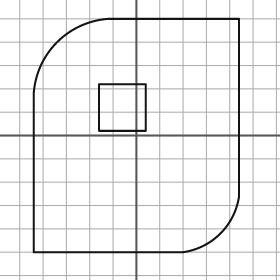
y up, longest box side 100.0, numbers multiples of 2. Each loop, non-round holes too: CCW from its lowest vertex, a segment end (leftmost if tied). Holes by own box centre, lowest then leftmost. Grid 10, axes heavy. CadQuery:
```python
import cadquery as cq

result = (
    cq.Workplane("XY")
    .moveTo(-44.0, -50.0)
    .lineTo(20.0, -50.0)
    .threePointArc((36.0, -42.0), (44.0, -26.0))
    .lineTo(44.0, 50.0)
    .lineTo(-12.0, 50.0)
    .threePointArc((-34.0, 40.0), (-44.0, 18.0))
    .close()
    .moveTo(-16.0, 2.0)
    .lineTo(4.0, 2.0)
    .lineTo(4.0, 22.0)
    .lineTo(-16.0, 22.0)
    .close()
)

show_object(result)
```